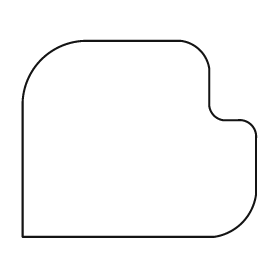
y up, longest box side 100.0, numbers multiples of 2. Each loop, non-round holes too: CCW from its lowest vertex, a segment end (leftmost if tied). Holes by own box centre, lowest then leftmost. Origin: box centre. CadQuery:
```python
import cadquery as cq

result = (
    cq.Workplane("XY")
    .moveTo(-50.0, -42.0)
    .lineTo(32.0, -42.0)
    .threePointArc((44.0, -36.0), (50.0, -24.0))
    .lineTo(50.0, 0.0)
    .threePointArc((48.0, 6.0), (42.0, 8.0))
    .lineTo(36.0, 8.0)
    .threePointArc((32.0, 10.0), (30.0, 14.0))
    .lineTo(30.0, 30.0)
    .threePointArc((26.0, 38.0), (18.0, 42.0))
    .lineTo(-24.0, 42.0)
    .threePointArc((-42.0, 34.0), (-50.0, 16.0))
    .close()
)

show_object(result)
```